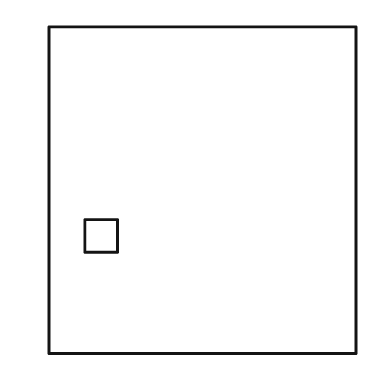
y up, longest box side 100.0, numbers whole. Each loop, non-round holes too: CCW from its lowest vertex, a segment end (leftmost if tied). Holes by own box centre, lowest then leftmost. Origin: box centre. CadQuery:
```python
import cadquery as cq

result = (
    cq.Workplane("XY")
    .moveTo(-47.0, -50.0)
    .lineTo(47.0, -50.0)
    .lineTo(47.0, 50.0)
    .lineTo(-47.0, 50.0)
    .close()
    .moveTo(-36.0, -19.0)
    .lineTo(-26.0, -19.0)
    .lineTo(-26.0, -9.0)
    .lineTo(-36.0, -9.0)
    .close()
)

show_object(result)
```